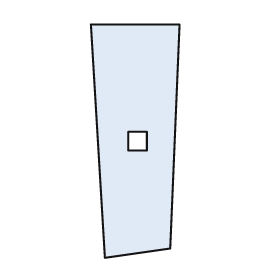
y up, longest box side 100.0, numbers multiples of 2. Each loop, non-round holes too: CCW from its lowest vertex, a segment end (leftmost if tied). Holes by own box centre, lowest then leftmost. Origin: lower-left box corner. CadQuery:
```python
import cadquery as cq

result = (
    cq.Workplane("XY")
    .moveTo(6.0, 0.0)
    .lineTo(34.0, 4.0)
    .lineTo(38.0, 100.0)
    .lineTo(0.0, 100.0)
    .close()
    .moveTo(16.0, 46.0)
    .lineTo(24.0, 46.0)
    .lineTo(24.0, 54.0)
    .lineTo(16.0, 54.0)
    .close()
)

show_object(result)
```